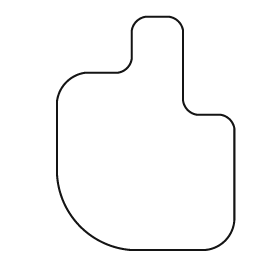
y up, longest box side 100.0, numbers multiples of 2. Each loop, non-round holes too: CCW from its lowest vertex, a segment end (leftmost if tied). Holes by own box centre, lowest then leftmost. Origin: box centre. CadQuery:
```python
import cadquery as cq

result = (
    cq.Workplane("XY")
    .moveTo(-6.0, -50.0)
    .lineTo(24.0, -50.0)
    .threePointArc((34.0, -46.0), (38.0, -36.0))
    .lineTo(38.0, 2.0)
    .threePointArc((36.0, 6.0), (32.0, 8.0))
    .lineTo(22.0, 8.0)
    .threePointArc((18.0, 10.0), (16.0, 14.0))
    .lineTo(16.0, 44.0)
    .threePointArc((14.0, 48.0), (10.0, 50.0))
    .lineTo(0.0, 50.0)
    .threePointArc((-4.0, 48.0), (-6.0, 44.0))
    .lineTo(-6.0, 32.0)
    .threePointArc((-8.0, 28.0), (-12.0, 26.0))
    .lineTo(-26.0, 26.0)
    .threePointArc((-34.0, 22.0), (-38.0, 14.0))
    .lineTo(-38.0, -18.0)
    .threePointArc((-28.0, -40.0), (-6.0, -50.0))
    .close()
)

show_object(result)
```